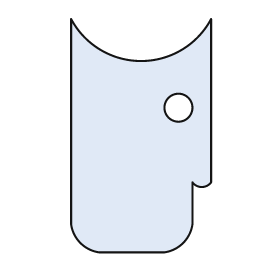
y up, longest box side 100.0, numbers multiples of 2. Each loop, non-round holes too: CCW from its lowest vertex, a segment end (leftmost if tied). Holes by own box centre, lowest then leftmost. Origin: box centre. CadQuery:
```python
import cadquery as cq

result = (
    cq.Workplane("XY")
    .moveTo(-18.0, -50.0)
    .lineTo(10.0, -50.0)
    .threePointArc((18.0, -46.0), (22.0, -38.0))
    .lineTo(22.0, -20.0)
    .threePointArc((26.0, -22.0), (30.0, -20.0))
    .lineTo(30.0, 50.0)
    .threePointArc((0.0, 32.0), (-30.0, 50.0))
    .lineTo(-30.0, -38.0)
    .threePointArc((-26.0, -46.0), (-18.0, -50.0))
    .close()
    .moveTo(16.0, 12.0)
    .circle(6.0)
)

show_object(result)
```